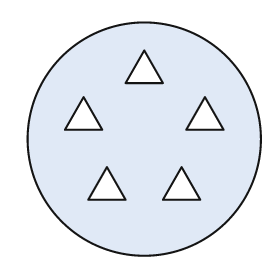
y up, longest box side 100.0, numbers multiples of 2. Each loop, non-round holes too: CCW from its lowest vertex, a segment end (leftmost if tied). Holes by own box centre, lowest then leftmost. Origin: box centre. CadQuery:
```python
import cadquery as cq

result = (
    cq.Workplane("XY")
    .moveTo(0.0, 0.0)
    .circle(50.0)
    .moveTo(-24.0, -26.0)
    .lineTo(-8.0, -26.0)
    .lineTo(-16.0, -12.0)
    .close()
    .moveTo(8.0, -26.0)
    .lineTo(24.0, -26.0)
    .lineTo(16.0, -12.0)
    .close()
    .moveTo(-34.0, 4.0)
    .lineTo(-18.0, 4.0)
    .lineTo(-26.0, 18.0)
    .close()
    .moveTo(18.0, 4.0)
    .lineTo(34.0, 4.0)
    .lineTo(26.0, 18.0)
    .close()
    .moveTo(-8.0, 24.0)
    .lineTo(8.0, 24.0)
    .lineTo(0.0, 38.0)
    .close()
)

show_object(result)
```